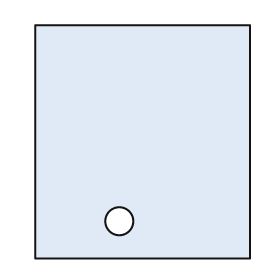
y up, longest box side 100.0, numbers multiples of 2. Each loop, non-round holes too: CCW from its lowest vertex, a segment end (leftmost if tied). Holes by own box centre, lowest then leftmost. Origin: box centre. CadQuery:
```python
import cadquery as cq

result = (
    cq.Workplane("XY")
    .moveTo(-46.0, -50.0)
    .lineTo(46.0, -50.0)
    .lineTo(46.0, 50.0)
    .lineTo(-46.0, 50.0)
    .close()
    .moveTo(-10.0, -34.0)
    .circle(6.0)
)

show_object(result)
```